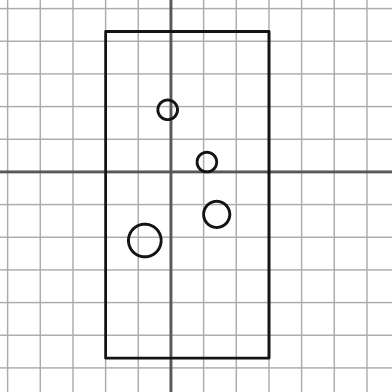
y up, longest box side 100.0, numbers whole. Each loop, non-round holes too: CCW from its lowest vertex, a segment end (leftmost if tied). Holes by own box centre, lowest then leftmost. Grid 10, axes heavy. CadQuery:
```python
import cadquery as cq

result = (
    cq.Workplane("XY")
    .moveTo(-20.0, -57.0)
    .lineTo(30.0, -57.0)
    .lineTo(30.0, 43.0)
    .lineTo(-20.0, 43.0)
    .close()
    .moveTo(-8.0, -21.0)
    .circle(5.0)
    .moveTo(14.0, -13.0)
    .circle(4.0)
    .moveTo(11.0, 3.0)
    .circle(3.0)
    .moveTo(-1.0, 19.0)
    .circle(3.0)
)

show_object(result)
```